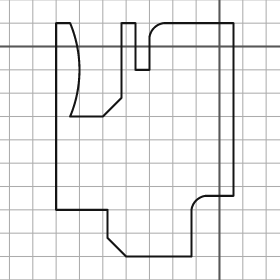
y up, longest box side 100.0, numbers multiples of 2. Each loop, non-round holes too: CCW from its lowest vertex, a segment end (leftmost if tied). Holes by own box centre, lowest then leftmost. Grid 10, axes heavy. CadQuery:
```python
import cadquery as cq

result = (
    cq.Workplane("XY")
    .moveTo(-40.0, -90.0)
    .lineTo(-12.0, -90.0)
    .lineTo(-12.0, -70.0)
    .threePointArc((-10.0, -66.0), (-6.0, -64.0))
    .lineTo(6.0, -64.0)
    .lineTo(6.0, 10.0)
    .lineTo(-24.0, 10.0)
    .threePointArc((-28.0, 8.0), (-30.0, 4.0))
    .lineTo(-30.0, -10.0)
    .lineTo(-36.0, -10.0)
    .lineTo(-36.0, 10.0)
    .lineTo(-42.0, 10.0)
    .lineTo(-42.0, -22.0)
    .lineTo(-50.0, -30.0)
    .lineTo(-64.0, -30.0)
    .threePointArc((-60.0, -10.0), (-64.0, 10.0))
    .lineTo(-70.0, 10.0)
    .lineTo(-70.0, -70.0)
    .lineTo(-48.0, -70.0)
    .lineTo(-48.0, -82.0)
    .close()
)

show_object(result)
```